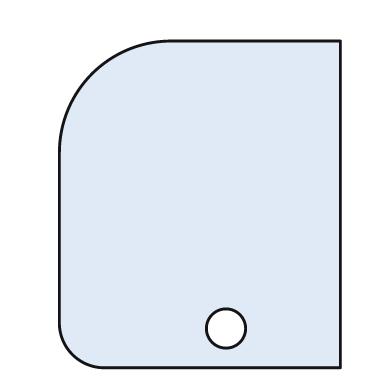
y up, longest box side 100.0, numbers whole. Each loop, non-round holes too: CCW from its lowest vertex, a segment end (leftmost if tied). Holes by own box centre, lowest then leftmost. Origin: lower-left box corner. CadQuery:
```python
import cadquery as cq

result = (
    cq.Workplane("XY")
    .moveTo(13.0, 0.0)
    .lineTo(86.0, 0.0)
    .lineTo(86.0, 100.0)
    .lineTo(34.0, 100.0)
    .threePointArc((10.0, 90.0), (0.0, 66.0))
    .lineTo(0.0, 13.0)
    .threePointArc((4.0, 4.0), (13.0, 0.0))
    .close()
    .moveTo(51.0, 12.0)
    .circle(6.0)
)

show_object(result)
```